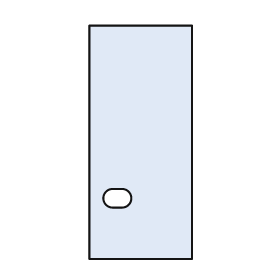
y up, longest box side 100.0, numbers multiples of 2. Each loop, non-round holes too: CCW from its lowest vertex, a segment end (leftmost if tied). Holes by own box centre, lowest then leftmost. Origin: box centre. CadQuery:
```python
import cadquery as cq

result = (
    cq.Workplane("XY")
    .moveTo(-22.0, -50.0)
    .lineTo(22.0, -50.0)
    .lineTo(22.0, 50.0)
    .lineTo(-22.0, 50.0)
    .close()
    .moveTo(-12.0, -28.0)
    .lineTo(-8.0, -28.0)
    .threePointArc((-4.0, -24.0), (-8.0, -20.0))
    .lineTo(-12.0, -20.0)
    .threePointArc((-16.0, -24.0), (-12.0, -28.0))
    .close()
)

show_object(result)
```